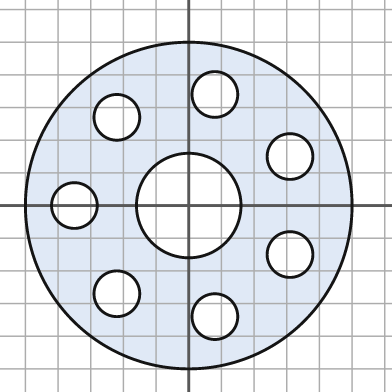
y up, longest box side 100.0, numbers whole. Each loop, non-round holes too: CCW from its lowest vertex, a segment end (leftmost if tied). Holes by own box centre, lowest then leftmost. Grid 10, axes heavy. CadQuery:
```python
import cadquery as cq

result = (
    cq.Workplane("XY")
    .moveTo(0.0, 0.0)
    .circle(50.0)
    .moveTo(8.0, -34.0)
    .circle(7.0)
    .moveTo(-22.0, -27.0)
    .circle(7.0)
    .moveTo(31.0, -15.0)
    .circle(7.0)
    .moveTo(-35.0, 0.0)
    .circle(7.0)
    .moveTo(0.0, 0.0)
    .circle(16.0)
    .moveTo(31.0, 15.0)
    .circle(7.0)
    .moveTo(-22.0, 27.0)
    .circle(7.0)
    .moveTo(8.0, 34.0)
    .circle(7.0)
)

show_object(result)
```